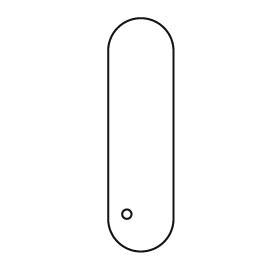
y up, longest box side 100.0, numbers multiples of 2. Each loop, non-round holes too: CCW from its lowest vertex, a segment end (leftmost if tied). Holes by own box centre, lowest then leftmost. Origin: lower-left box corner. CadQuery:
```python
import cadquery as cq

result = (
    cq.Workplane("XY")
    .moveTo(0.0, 14.0)
    .threePointArc((14.0, 0.0), (28.0, 14.0))
    .lineTo(28.0, 86.0)
    .threePointArc((14.0, 100.0), (0.0, 86.0))
    .close()
    .moveTo(8.0, 16.0)
    .circle(2.0)
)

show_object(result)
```